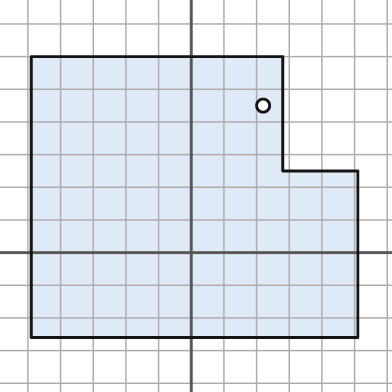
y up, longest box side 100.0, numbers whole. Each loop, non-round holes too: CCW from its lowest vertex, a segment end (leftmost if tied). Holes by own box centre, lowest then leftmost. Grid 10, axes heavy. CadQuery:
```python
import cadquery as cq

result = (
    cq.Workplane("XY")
    .moveTo(-49.0, -26.0)
    .lineTo(51.0, -26.0)
    .lineTo(51.0, 25.0)
    .lineTo(28.0, 25.0)
    .lineTo(28.0, 60.0)
    .lineTo(-49.0, 60.0)
    .close()
    .moveTo(22.0, 45.0)
    .circle(2.0)
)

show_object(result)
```